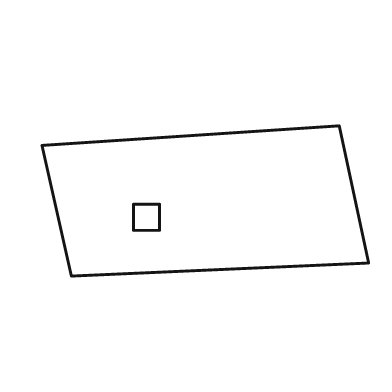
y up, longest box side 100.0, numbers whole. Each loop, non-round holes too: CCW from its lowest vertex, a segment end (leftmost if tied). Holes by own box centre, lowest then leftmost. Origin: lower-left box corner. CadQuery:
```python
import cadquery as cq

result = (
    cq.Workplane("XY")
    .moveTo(9.0, 0.0)
    .lineTo(100.0, 4.0)
    .lineTo(91.0, 46.0)
    .lineTo(0.0, 40.0)
    .close()
    .moveTo(28.0, 14.0)
    .lineTo(36.0, 14.0)
    .lineTo(36.0, 22.0)
    .lineTo(28.0, 22.0)
    .close()
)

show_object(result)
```